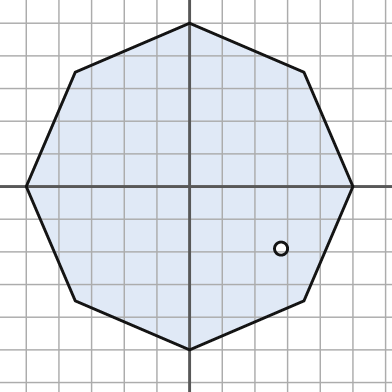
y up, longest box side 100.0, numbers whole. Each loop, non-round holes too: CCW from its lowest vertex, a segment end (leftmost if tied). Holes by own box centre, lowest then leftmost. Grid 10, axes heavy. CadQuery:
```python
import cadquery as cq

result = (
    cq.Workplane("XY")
    .moveTo(0.0, -50.0)
    .lineTo(35.0, -35.0)
    .lineTo(50.0, 0.0)
    .lineTo(35.0, 35.0)
    .lineTo(0.0, 50.0)
    .lineTo(-35.0, 35.0)
    .lineTo(-50.0, 0.0)
    .lineTo(-35.0, -35.0)
    .close()
    .moveTo(28.0, -19.0)
    .circle(2.0)
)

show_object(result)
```